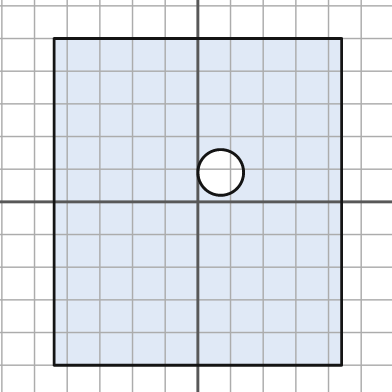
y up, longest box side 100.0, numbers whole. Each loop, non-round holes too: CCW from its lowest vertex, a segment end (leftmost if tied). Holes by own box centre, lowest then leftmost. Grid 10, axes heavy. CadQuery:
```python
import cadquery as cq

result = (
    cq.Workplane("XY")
    .moveTo(-44.0, -50.0)
    .lineTo(44.0, -50.0)
    .lineTo(44.0, 50.0)
    .lineTo(-44.0, 50.0)
    .close()
    .moveTo(7.0, 9.0)
    .circle(7.0)
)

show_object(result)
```